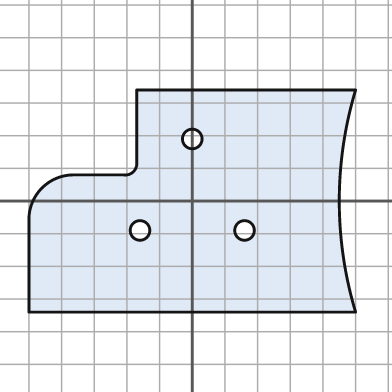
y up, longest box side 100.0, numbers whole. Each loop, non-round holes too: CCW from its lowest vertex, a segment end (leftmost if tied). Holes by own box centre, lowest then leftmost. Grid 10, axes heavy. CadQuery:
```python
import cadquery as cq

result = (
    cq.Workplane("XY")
    .moveTo(-50.0, -34.0)
    .lineTo(50.0, -34.0)
    .threePointArc((45.0, 0.0), (50.0, 34.0))
    .lineTo(-17.0, 34.0)
    .lineTo(-17.0, 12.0)
    .threePointArc((-18.0, 9.0), (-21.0, 8.0))
    .lineTo(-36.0, 8.0)
    .threePointArc((-46.0, 4.0), (-50.0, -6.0))
    .close()
    .moveTo(-16.0, -9.0)
    .circle(3.0)
    .moveTo(16.0, -9.0)
    .circle(3.0)
    .moveTo(0.0, 19.0)
    .circle(3.0)
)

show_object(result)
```